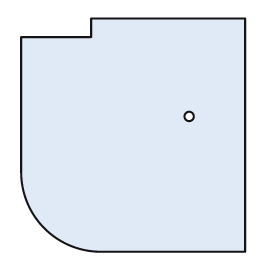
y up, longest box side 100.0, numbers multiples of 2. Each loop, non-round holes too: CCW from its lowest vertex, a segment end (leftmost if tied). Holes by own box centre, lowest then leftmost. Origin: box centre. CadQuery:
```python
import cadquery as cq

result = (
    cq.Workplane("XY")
    .moveTo(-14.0, -50.0)
    .lineTo(48.0, -50.0)
    .lineTo(48.0, 50.0)
    .lineTo(-18.0, 50.0)
    .lineTo(-18.0, 42.0)
    .lineTo(-48.0, 42.0)
    .lineTo(-48.0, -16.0)
    .threePointArc((-38.0, -40.0), (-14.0, -50.0))
    .close()
    .moveTo(24.0, 8.0)
    .circle(2.0)
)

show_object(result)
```